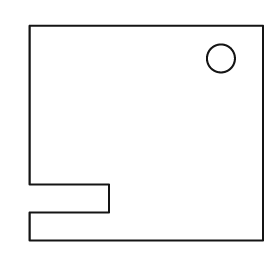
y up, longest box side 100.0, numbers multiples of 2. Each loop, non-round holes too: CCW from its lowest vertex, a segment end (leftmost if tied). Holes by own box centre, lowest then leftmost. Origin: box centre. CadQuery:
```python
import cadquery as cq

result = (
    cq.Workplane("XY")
    .moveTo(-50.0, -46.0)
    .lineTo(50.0, -46.0)
    .lineTo(50.0, 46.0)
    .lineTo(-50.0, 46.0)
    .lineTo(-50.0, -22.0)
    .lineTo(-16.0, -22.0)
    .lineTo(-16.0, -34.0)
    .lineTo(-50.0, -34.0)
    .close()
    .moveTo(32.0, 32.0)
    .circle(6.0)
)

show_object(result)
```